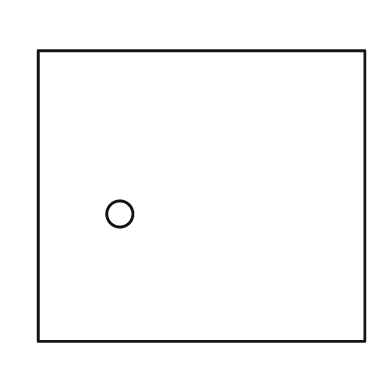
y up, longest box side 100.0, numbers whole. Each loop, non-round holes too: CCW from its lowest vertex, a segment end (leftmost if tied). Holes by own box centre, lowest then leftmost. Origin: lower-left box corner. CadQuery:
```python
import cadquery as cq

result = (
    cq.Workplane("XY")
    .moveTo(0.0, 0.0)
    .lineTo(100.0, 0.0)
    .lineTo(100.0, 89.0)
    .lineTo(0.0, 89.0)
    .close()
    .moveTo(25.0, 39.0)
    .circle(4.0)
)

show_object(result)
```